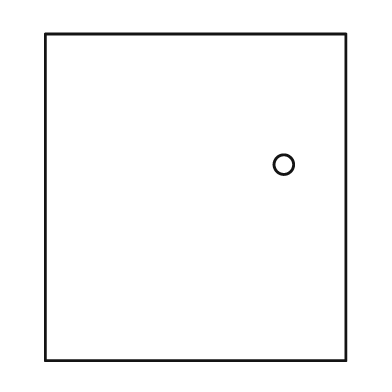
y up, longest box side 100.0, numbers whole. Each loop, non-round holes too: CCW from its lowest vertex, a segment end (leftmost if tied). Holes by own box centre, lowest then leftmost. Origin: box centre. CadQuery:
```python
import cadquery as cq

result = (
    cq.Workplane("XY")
    .moveTo(-46.0, -50.0)
    .lineTo(46.0, -50.0)
    .lineTo(46.0, 50.0)
    .lineTo(-46.0, 50.0)
    .close()
    .moveTo(27.0, 10.0)
    .circle(3.0)
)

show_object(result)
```